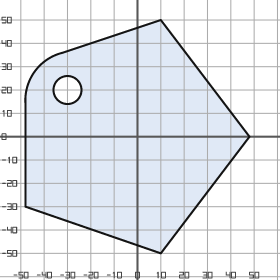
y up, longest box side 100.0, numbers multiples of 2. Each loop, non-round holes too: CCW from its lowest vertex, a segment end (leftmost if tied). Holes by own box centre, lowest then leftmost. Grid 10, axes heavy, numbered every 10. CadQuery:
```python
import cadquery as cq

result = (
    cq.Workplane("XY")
    .moveTo(10.0, -50.0)
    .lineTo(48.0, 0.0)
    .lineTo(10.0, 50.0)
    .lineTo(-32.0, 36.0)
    .threePointArc((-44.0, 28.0), (-48.0, 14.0))
    .lineTo(-48.0, -30.0)
    .close()
    .moveTo(-30.0, 20.0)
    .circle(6.0)
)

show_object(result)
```